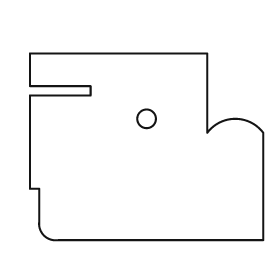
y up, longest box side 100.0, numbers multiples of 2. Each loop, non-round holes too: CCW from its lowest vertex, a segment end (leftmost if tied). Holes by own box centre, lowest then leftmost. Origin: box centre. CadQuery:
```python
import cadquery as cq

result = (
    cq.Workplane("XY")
    .moveTo(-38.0, -40.0)
    .lineTo(50.0, -40.0)
    .lineTo(50.0, 6.0)
    .threePointArc((38.0, 12.0), (26.0, 6.0))
    .lineTo(26.0, 40.0)
    .lineTo(-50.0, 40.0)
    .lineTo(-50.0, 26.0)
    .lineTo(-24.0, 26.0)
    .lineTo(-24.0, 22.0)
    .lineTo(-50.0, 22.0)
    .lineTo(-50.0, -18.0)
    .lineTo(-46.0, -18.0)
    .lineTo(-46.0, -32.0)
    .threePointArc((-44.0, -38.0), (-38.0, -40.0))
    .close()
    .moveTo(0.0, 12.0)
    .circle(4.0)
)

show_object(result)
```